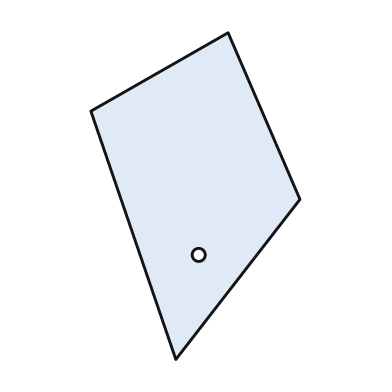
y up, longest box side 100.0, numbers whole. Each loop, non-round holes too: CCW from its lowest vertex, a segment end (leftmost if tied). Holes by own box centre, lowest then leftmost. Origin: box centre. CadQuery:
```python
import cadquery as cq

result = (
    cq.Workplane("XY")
    .moveTo(-6.0, -50.0)
    .lineTo(32.0, -1.0)
    .lineTo(10.0, 50.0)
    .lineTo(-32.0, 26.0)
    .close()
    .moveTo(1.0, -18.0)
    .circle(2.0)
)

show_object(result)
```